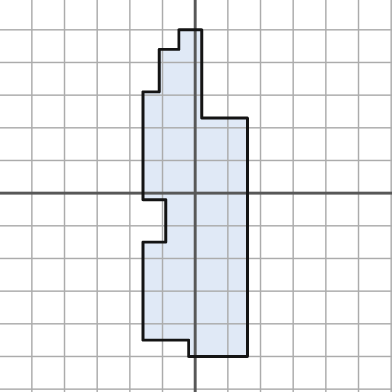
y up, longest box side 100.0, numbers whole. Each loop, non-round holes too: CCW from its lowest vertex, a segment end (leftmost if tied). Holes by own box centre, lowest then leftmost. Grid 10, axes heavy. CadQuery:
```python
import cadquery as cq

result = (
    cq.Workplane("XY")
    .moveTo(-2.0, -50.0)
    .lineTo(16.0, -50.0)
    .lineTo(16.0, 23.0)
    .lineTo(2.0, 23.0)
    .lineTo(2.0, 50.0)
    .lineTo(-5.0, 50.0)
    .lineTo(-5.0, 44.0)
    .lineTo(-11.0, 44.0)
    .lineTo(-11.0, 31.0)
    .lineTo(-16.0, 31.0)
    .lineTo(-16.0, -2.0)
    .lineTo(-9.0, -2.0)
    .lineTo(-9.0, -15.0)
    .lineTo(-16.0, -15.0)
    .lineTo(-16.0, -45.0)
    .lineTo(-2.0, -45.0)
    .close()
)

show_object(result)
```